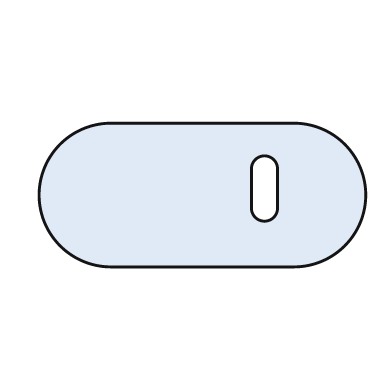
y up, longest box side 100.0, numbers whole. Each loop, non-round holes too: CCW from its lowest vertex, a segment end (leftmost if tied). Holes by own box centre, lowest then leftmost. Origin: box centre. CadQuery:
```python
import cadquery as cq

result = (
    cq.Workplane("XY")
    .moveTo(-28.0, -22.0)
    .lineTo(28.0, -22.0)
    .threePointArc((50.0, 0.0), (28.0, 22.0))
    .lineTo(-28.0, 22.0)
    .threePointArc((-50.0, 0.0), (-28.0, -22.0))
    .close()
    .moveTo(15.0, -4.0)
    .threePointArc((19.0, -8.0), (23.0, -4.0))
    .lineTo(23.0, 8.0)
    .threePointArc((19.0, 12.0), (15.0, 8.0))
    .close()
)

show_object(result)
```